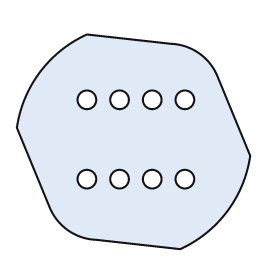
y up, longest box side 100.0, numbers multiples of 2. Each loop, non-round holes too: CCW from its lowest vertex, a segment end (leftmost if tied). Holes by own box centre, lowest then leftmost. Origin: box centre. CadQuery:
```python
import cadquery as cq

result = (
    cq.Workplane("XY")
    .moveTo(20.0, -46.0)
    .threePointArc((40.0, -30.0), (50.0, -6.0))
    .lineTo(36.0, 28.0)
    .threePointArc((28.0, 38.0), (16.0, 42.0))
    .lineTo(-20.0, 46.0)
    .threePointArc((-40.0, 30.0), (-50.0, 6.0))
    .lineTo(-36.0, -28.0)
    .threePointArc((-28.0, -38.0), (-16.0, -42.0))
    .close()
    .moveTo(-20.0, -16.0)
    .circle(4.0)
    .moveTo(-6.0, -16.0)
    .circle(4.0)
    .moveTo(8.0, -16.0)
    .circle(4.0)
    .moveTo(22.0, -16.0)
    .circle(4.0)
    .moveTo(-20.0, 18.0)
    .circle(4.0)
    .moveTo(-6.0, 18.0)
    .circle(4.0)
    .moveTo(8.0, 18.0)
    .circle(4.0)
    .moveTo(22.0, 18.0)
    .circle(4.0)
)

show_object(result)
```